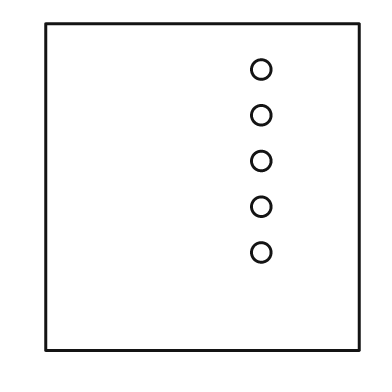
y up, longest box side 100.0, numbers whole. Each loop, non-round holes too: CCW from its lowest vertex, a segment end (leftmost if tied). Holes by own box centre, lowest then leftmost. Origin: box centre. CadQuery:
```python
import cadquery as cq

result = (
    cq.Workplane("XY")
    .moveTo(-48.0, -50.0)
    .lineTo(48.0, -50.0)
    .lineTo(48.0, 50.0)
    .lineTo(-48.0, 50.0)
    .close()
    .moveTo(18.0, -20.0)
    .circle(3.0)
    .moveTo(18.0, -6.0)
    .circle(3.0)
    .moveTo(18.0, 8.0)
    .circle(3.0)
    .moveTo(18.0, 22.0)
    .circle(3.0)
    .moveTo(18.0, 36.0)
    .circle(3.0)
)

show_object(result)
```